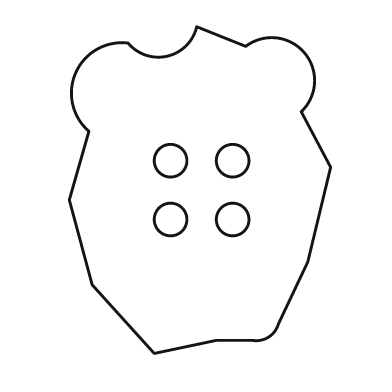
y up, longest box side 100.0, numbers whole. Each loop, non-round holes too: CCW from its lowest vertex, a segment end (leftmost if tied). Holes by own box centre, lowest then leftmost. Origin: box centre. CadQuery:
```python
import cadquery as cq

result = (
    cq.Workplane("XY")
    .moveTo(-14.0, -50.0)
    .lineTo(5.0, -46.0)
    .lineTo(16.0, -46.0)
    .threePointArc((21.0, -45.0), (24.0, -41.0))
    .lineTo(33.0, -22.0)
    .lineTo(40.0, 7.0)
    .lineTo(31.0, 24.0)
    .threePointArc((32.0, 42.0), (14.0, 44.0))
    .lineTo(-1.0, 50.0)
    .threePointArc((-10.0, 41.0), (-22.0, 45.0))
    .threePointArc((-38.0, 36.0), (-34.0, 18.0))
    .lineTo(-40.0, -3.0)
    .lineTo(-33.0, -29.0)
    .close()
    .moveTo(-9.0, -9.0)
    .circle(5.0)
    .moveTo(10.0, -9.0)
    .circle(5.0)
    .moveTo(-9.0, 9.0)
    .circle(5.0)
    .moveTo(10.0, 9.0)
    .circle(5.0)
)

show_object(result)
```